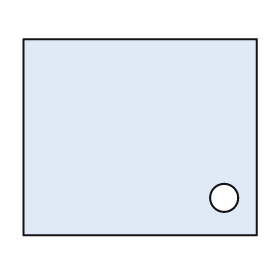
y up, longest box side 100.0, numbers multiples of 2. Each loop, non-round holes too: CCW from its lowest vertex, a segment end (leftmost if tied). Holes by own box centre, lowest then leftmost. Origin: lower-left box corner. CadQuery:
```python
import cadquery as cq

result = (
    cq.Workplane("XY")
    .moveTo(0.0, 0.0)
    .lineTo(100.0, 0.0)
    .lineTo(100.0, 84.0)
    .lineTo(0.0, 84.0)
    .close()
    .moveTo(86.0, 16.0)
    .circle(6.0)
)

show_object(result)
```